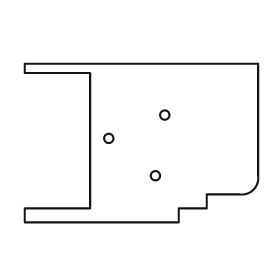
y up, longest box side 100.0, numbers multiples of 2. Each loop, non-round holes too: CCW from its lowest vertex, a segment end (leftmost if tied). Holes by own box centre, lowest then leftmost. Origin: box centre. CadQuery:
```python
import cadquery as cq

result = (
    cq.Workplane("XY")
    .moveTo(-50.0, -34.0)
    .lineTo(16.0, -34.0)
    .lineTo(16.0, -28.0)
    .lineTo(28.0, -28.0)
    .lineTo(28.0, -22.0)
    .lineTo(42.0, -22.0)
    .threePointArc((48.0, -20.0), (50.0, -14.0))
    .lineTo(50.0, 34.0)
    .lineTo(-50.0, 34.0)
    .lineTo(-50.0, 30.0)
    .lineTo(-22.0, 30.0)
    .lineTo(-22.0, -28.0)
    .lineTo(-50.0, -28.0)
    .close()
    .moveTo(6.0, -14.0)
    .circle(2.0)
    .moveTo(-14.0, 2.0)
    .circle(2.0)
    .moveTo(10.0, 12.0)
    .circle(2.0)
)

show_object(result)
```